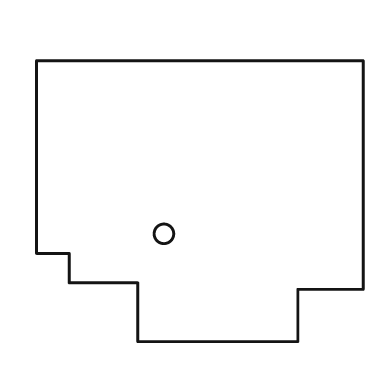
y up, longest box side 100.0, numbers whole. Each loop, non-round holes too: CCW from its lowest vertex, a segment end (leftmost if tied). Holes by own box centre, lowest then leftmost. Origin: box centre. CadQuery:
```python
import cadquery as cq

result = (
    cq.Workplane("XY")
    .moveTo(-19.0, -43.0)
    .lineTo(30.0, -43.0)
    .lineTo(30.0, -27.0)
    .lineTo(50.0, -27.0)
    .lineTo(50.0, 43.0)
    .lineTo(-50.0, 43.0)
    .lineTo(-50.0, -16.0)
    .lineTo(-40.0, -16.0)
    .lineTo(-40.0, -25.0)
    .lineTo(-19.0, -25.0)
    .close()
    .moveTo(-11.0, -10.0)
    .circle(3.0)
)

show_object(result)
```